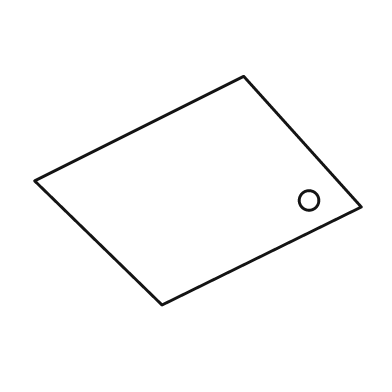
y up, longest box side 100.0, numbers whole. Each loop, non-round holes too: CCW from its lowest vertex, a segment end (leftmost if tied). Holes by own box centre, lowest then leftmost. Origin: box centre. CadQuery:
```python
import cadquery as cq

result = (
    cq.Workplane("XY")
    .moveTo(-11.0, -35.0)
    .lineTo(50.0, -5.0)
    .lineTo(14.0, 35.0)
    .lineTo(-50.0, 3.0)
    .close()
    .moveTo(34.0, -3.0)
    .circle(3.0)
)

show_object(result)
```